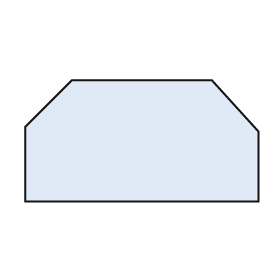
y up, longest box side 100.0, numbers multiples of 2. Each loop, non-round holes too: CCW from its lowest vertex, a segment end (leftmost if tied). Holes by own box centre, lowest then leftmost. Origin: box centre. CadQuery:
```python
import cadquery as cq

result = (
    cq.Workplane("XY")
    .moveTo(-50.0, -26.0)
    .lineTo(50.0, -26.0)
    .lineTo(50.0, 4.0)
    .lineTo(30.0, 26.0)
    .lineTo(-30.0, 26.0)
    .lineTo(-50.0, 6.0)
    .close()
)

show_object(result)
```